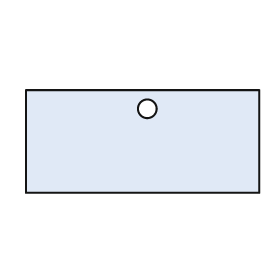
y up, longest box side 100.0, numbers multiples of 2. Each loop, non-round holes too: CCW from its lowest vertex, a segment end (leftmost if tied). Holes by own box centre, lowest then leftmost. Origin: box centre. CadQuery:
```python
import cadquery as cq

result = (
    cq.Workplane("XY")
    .moveTo(-50.0, -22.0)
    .lineTo(50.0, -22.0)
    .lineTo(50.0, 22.0)
    .lineTo(-50.0, 22.0)
    .close()
    .moveTo(2.0, 14.0)
    .circle(4.0)
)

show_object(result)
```